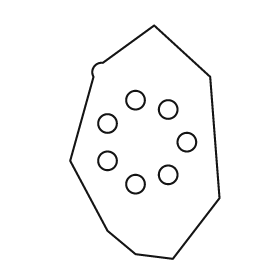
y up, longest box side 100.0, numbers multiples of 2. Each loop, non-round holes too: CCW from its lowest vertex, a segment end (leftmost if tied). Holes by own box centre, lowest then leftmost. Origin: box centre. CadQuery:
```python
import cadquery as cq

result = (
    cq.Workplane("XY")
    .moveTo(12.0, -50.0)
    .lineTo(32.0, -24.0)
    .lineTo(28.0, 28.0)
    .lineTo(4.0, 50.0)
    .lineTo(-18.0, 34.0)
    .threePointArc((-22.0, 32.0), (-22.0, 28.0))
    .lineTo(-32.0, -8.0)
    .lineTo(-16.0, -38.0)
    .lineTo(-4.0, -48.0)
    .close()
    .moveTo(-4.0, -18.0)
    .circle(4.0)
    .moveTo(10.0, -14.0)
    .circle(4.0)
    .moveTo(-16.0, -8.0)
    .circle(4.0)
    .moveTo(18.0, 0.0)
    .circle(4.0)
    .moveTo(-16.0, 8.0)
    .circle(4.0)
    .moveTo(10.0, 14.0)
    .circle(4.0)
    .moveTo(-4.0, 18.0)
    .circle(4.0)
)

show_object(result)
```